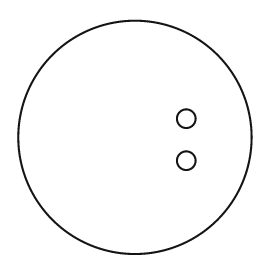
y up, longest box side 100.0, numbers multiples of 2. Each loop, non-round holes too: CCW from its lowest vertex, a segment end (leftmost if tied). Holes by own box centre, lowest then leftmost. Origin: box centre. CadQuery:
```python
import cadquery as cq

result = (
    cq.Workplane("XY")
    .moveTo(0.0, 0.0)
    .circle(50.0)
    .moveTo(22.0, -10.0)
    .circle(4.0)
    .moveTo(22.0, 8.0)
    .circle(4.0)
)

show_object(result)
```